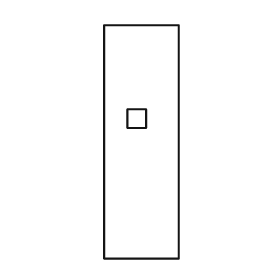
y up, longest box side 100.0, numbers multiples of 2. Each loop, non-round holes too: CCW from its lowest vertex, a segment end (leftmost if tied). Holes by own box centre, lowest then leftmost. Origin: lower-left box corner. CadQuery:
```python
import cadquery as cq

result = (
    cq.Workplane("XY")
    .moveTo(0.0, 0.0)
    .lineTo(32.0, 0.0)
    .lineTo(32.0, 100.0)
    .lineTo(0.0, 100.0)
    .close()
    .moveTo(10.0, 56.0)
    .lineTo(18.0, 56.0)
    .lineTo(18.0, 64.0)
    .lineTo(10.0, 64.0)
    .close()
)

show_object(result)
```